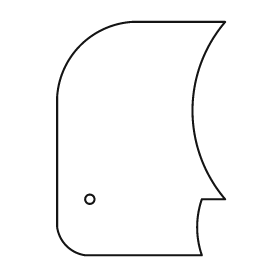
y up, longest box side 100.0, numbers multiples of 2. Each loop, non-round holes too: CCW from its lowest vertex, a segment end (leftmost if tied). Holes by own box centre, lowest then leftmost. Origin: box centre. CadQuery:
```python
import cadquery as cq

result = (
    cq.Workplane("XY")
    .moveTo(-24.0, -50.0)
    .lineTo(26.0, -50.0)
    .threePointArc((24.0, -38.0), (26.0, -26.0))
    .lineTo(36.0, -26.0)
    .threePointArc((22.0, 12.0), (36.0, 50.0))
    .lineTo(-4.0, 50.0)
    .threePointArc((-26.0, 40.0), (-36.0, 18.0))
    .lineTo(-36.0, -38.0)
    .threePointArc((-32.0, -46.0), (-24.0, -50.0))
    .close()
    .moveTo(-22.0, -26.0)
    .circle(2.0)
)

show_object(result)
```